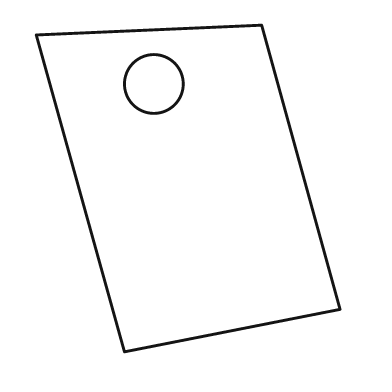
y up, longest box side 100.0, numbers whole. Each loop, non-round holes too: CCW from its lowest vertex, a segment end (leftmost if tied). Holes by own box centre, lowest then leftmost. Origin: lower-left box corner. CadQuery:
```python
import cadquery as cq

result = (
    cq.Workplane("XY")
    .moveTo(27.0, 0.0)
    .lineTo(93.0, 13.0)
    .lineTo(69.0, 100.0)
    .lineTo(0.0, 97.0)
    .close()
    .moveTo(36.0, 82.0)
    .circle(9.0)
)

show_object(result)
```